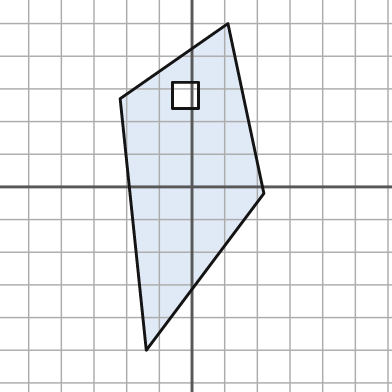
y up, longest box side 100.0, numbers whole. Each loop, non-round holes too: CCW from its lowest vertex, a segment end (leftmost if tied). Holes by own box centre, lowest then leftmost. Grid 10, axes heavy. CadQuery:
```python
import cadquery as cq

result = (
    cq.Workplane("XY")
    .moveTo(-14.0, -50.0)
    .lineTo(22.0, -2.0)
    .lineTo(11.0, 50.0)
    .lineTo(-22.0, 27.0)
    .close()
    .moveTo(-6.0, 24.0)
    .lineTo(2.0, 24.0)
    .lineTo(2.0, 32.0)
    .lineTo(-6.0, 32.0)
    .close()
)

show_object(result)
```